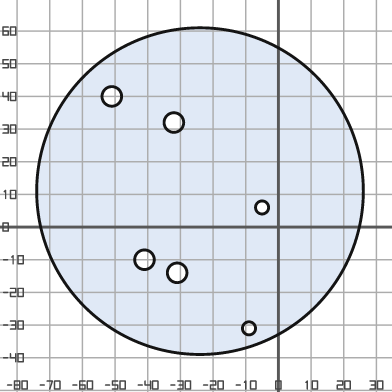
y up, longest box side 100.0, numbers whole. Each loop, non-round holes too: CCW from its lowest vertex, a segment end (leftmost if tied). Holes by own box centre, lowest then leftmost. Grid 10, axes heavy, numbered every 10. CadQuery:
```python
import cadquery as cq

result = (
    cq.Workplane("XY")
    .moveTo(-24.0, 11.0)
    .circle(50.0)
    .moveTo(-9.0, -31.0)
    .circle(2.0)
    .moveTo(-31.0, -14.0)
    .circle(3.0)
    .moveTo(-41.0, -10.0)
    .circle(3.0)
    .moveTo(-5.0, 6.0)
    .circle(2.0)
    .moveTo(-32.0, 32.0)
    .circle(3.0)
    .moveTo(-51.0, 40.0)
    .circle(3.0)
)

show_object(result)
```